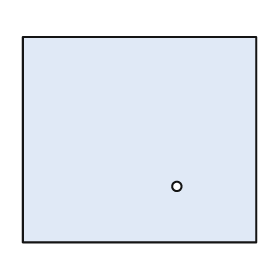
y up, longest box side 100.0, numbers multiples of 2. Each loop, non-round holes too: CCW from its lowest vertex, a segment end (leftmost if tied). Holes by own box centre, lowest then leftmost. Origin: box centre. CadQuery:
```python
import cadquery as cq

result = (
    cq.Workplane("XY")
    .moveTo(-50.0, -44.0)
    .lineTo(50.0, -44.0)
    .lineTo(50.0, 44.0)
    .lineTo(-50.0, 44.0)
    .close()
    .moveTo(16.0, -20.0)
    .circle(2.0)
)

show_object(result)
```